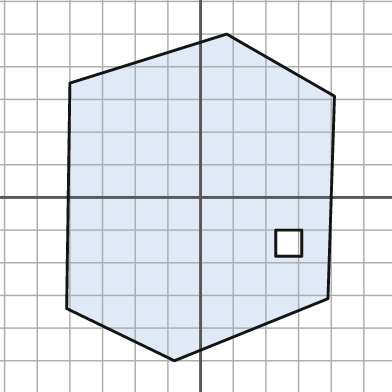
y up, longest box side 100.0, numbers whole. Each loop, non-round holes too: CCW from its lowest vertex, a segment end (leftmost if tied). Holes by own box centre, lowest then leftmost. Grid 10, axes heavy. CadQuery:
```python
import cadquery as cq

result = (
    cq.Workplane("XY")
    .moveTo(-8.0, -50.0)
    .lineTo(39.0, -31.0)
    .lineTo(41.0, 31.0)
    .lineTo(8.0, 50.0)
    .lineTo(-40.0, 35.0)
    .lineTo(-41.0, -34.0)
    .close()
    .moveTo(23.0, -18.0)
    .lineTo(31.0, -18.0)
    .lineTo(31.0, -10.0)
    .lineTo(23.0, -10.0)
    .close()
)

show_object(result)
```